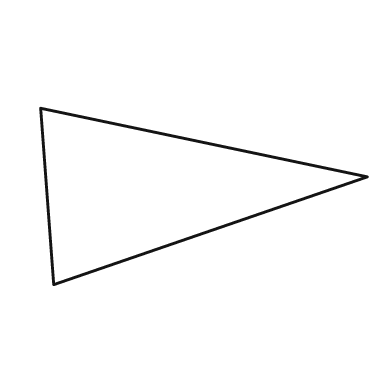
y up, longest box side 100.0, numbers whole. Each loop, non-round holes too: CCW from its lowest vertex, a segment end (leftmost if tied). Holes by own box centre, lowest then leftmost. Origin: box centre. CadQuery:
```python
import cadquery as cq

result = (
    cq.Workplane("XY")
    .moveTo(-46.0, -27.0)
    .lineTo(50.0, 6.0)
    .lineTo(-50.0, 27.0)
    .close()
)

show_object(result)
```